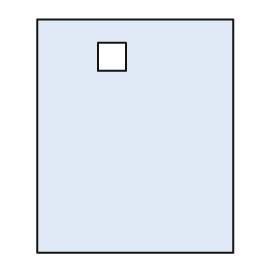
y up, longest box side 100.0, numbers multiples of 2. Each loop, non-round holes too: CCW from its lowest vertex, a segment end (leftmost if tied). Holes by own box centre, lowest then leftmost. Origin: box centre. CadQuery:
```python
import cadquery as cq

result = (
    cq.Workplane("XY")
    .moveTo(-42.0, -50.0)
    .lineTo(42.0, -50.0)
    .lineTo(42.0, 50.0)
    .lineTo(-42.0, 50.0)
    .close()
    .moveTo(-16.0, 28.0)
    .lineTo(-4.0, 28.0)
    .lineTo(-4.0, 40.0)
    .lineTo(-16.0, 40.0)
    .close()
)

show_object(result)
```